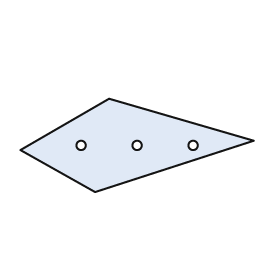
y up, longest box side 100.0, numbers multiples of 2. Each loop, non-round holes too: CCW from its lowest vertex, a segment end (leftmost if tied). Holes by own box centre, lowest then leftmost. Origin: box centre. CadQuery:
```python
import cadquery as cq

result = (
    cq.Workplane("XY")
    .moveTo(-18.0, -20.0)
    .lineTo(50.0, 2.0)
    .lineTo(-12.0, 20.0)
    .lineTo(-50.0, -2.0)
    .close()
    .moveTo(-24.0, 0.0)
    .circle(2.0)
    .moveTo(0.0, 0.0)
    .circle(2.0)
    .moveTo(24.0, 0.0)
    .circle(2.0)
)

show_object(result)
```